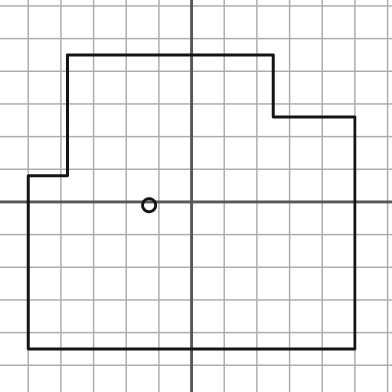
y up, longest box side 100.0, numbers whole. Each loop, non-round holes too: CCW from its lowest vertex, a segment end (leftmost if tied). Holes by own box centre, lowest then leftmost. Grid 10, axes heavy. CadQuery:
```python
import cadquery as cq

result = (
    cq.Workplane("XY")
    .moveTo(-50.0, -45.0)
    .lineTo(50.0, -45.0)
    .lineTo(50.0, 26.0)
    .lineTo(25.0, 26.0)
    .lineTo(25.0, 45.0)
    .lineTo(-38.0, 45.0)
    .lineTo(-38.0, 8.0)
    .lineTo(-50.0, 8.0)
    .close()
    .moveTo(-13.0, -1.0)
    .circle(2.0)
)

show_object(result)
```